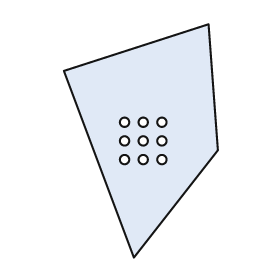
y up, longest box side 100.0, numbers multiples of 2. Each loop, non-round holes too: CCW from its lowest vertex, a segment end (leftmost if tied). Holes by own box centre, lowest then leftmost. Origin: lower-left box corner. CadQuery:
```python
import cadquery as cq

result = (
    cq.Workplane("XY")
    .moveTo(30.0, 0.0)
    .lineTo(66.0, 46.0)
    .lineTo(62.0, 100.0)
    .lineTo(0.0, 80.0)
    .close()
    .moveTo(26.0, 42.0)
    .circle(2.0)
    .moveTo(34.0, 42.0)
    .circle(2.0)
    .moveTo(42.0, 42.0)
    .circle(2.0)
    .moveTo(26.0, 50.0)
    .circle(2.0)
    .moveTo(34.0, 50.0)
    .circle(2.0)
    .moveTo(42.0, 50.0)
    .circle(2.0)
    .moveTo(26.0, 58.0)
    .circle(2.0)
    .moveTo(34.0, 58.0)
    .circle(2.0)
    .moveTo(42.0, 58.0)
    .circle(2.0)
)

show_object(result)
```